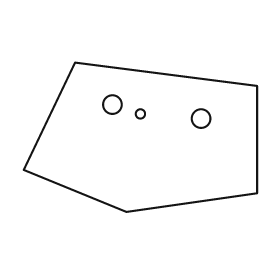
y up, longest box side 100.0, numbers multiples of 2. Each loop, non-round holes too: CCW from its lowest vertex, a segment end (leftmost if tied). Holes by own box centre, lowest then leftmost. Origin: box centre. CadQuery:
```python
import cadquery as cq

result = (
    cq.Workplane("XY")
    .moveTo(-6.0, -32.0)
    .lineTo(50.0, -24.0)
    .lineTo(50.0, 22.0)
    .lineTo(-28.0, 32.0)
    .lineTo(-50.0, -14.0)
    .close()
    .moveTo(26.0, 8.0)
    .circle(4.0)
    .moveTo(0.0, 10.0)
    .circle(2.0)
    .moveTo(-12.0, 14.0)
    .circle(4.0)
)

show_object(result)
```